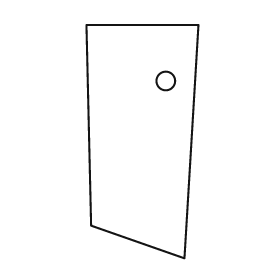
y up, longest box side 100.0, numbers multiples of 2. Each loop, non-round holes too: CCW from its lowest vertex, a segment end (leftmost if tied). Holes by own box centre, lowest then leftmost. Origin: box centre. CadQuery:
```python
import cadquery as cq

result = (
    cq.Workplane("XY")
    .moveTo(18.0, -50.0)
    .lineTo(24.0, 50.0)
    .lineTo(-24.0, 50.0)
    .lineTo(-22.0, -36.0)
    .close()
    .moveTo(10.0, 26.0)
    .circle(4.0)
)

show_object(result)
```